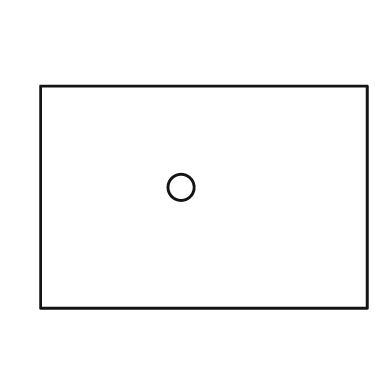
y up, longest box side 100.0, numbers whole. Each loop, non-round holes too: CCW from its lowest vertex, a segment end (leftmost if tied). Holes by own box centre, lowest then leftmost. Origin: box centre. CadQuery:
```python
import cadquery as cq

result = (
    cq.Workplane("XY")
    .moveTo(-50.0, -34.0)
    .lineTo(50.0, -34.0)
    .lineTo(50.0, 34.0)
    .lineTo(-50.0, 34.0)
    .close()
    .moveTo(-7.0, 3.0)
    .circle(4.0)
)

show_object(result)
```